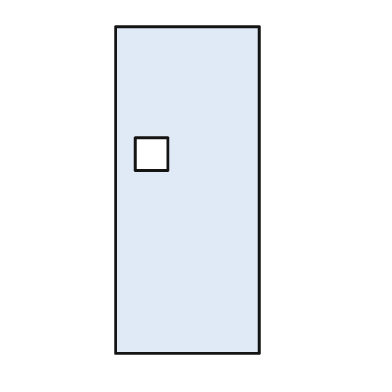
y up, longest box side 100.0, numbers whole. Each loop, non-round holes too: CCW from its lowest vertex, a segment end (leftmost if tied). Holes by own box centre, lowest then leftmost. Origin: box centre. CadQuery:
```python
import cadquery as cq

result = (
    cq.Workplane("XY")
    .moveTo(-22.0, -50.0)
    .lineTo(22.0, -50.0)
    .lineTo(22.0, 50.0)
    .lineTo(-22.0, 50.0)
    .close()
    .moveTo(-16.0, 6.0)
    .lineTo(-6.0, 6.0)
    .lineTo(-6.0, 16.0)
    .lineTo(-16.0, 16.0)
    .close()
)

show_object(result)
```